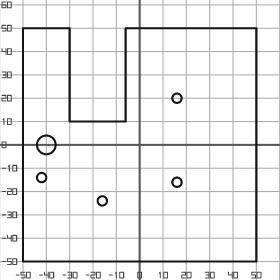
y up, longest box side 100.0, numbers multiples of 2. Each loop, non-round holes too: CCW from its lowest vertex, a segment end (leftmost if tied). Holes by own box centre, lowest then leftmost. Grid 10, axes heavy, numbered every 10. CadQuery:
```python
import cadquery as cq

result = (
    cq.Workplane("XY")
    .moveTo(-50.0, -50.0)
    .lineTo(50.0, -50.0)
    .lineTo(50.0, 50.0)
    .lineTo(-6.0, 50.0)
    .lineTo(-6.0, 10.0)
    .lineTo(-30.0, 10.0)
    .lineTo(-30.0, 50.0)
    .lineTo(-50.0, 50.0)
    .close()
    .moveTo(-16.0, -24.0)
    .circle(2.0)
    .moveTo(16.0, -16.0)
    .circle(2.0)
    .moveTo(-42.0, -14.0)
    .circle(2.0)
    .moveTo(-40.0, 0.0)
    .circle(4.0)
    .moveTo(16.0, 20.0)
    .circle(2.0)
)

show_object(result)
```